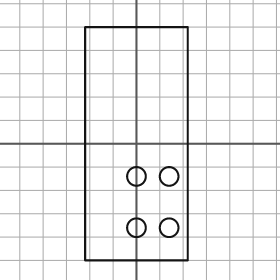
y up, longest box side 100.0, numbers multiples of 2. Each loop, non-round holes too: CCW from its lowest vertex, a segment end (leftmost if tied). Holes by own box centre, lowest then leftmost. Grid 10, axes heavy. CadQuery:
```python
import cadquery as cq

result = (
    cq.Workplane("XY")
    .moveTo(-22.0, -50.0)
    .lineTo(22.0, -50.0)
    .lineTo(22.0, 50.0)
    .lineTo(-22.0, 50.0)
    .close()
    .moveTo(0.0, -36.0)
    .circle(4.0)
    .moveTo(14.0, -36.0)
    .circle(4.0)
    .moveTo(0.0, -14.0)
    .circle(4.0)
    .moveTo(14.0, -14.0)
    .circle(4.0)
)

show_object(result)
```